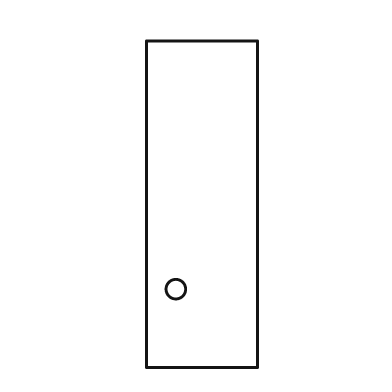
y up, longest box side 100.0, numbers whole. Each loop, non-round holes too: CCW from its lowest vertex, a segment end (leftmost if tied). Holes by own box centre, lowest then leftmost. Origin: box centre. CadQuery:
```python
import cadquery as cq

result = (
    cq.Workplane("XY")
    .moveTo(-17.0, -50.0)
    .lineTo(17.0, -50.0)
    .lineTo(17.0, 50.0)
    .lineTo(-17.0, 50.0)
    .close()
    .moveTo(-8.0, -26.0)
    .circle(3.0)
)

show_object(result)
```